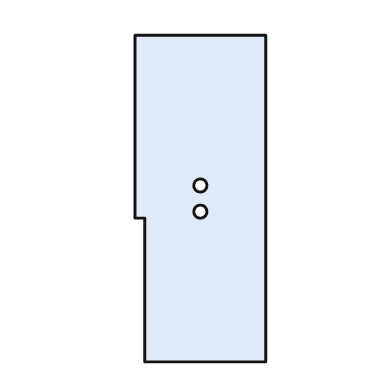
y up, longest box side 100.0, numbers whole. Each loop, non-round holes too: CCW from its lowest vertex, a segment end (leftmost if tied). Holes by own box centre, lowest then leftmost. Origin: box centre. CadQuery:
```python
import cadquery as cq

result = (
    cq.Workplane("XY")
    .moveTo(-17.0, -50.0)
    .lineTo(20.0, -50.0)
    .lineTo(20.0, 50.0)
    .lineTo(-20.0, 50.0)
    .lineTo(-20.0, -6.0)
    .lineTo(-17.0, -6.0)
    .close()
    .moveTo(0.0, -4.0)
    .circle(2.0)
    .moveTo(0.0, 4.0)
    .circle(2.0)
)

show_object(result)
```